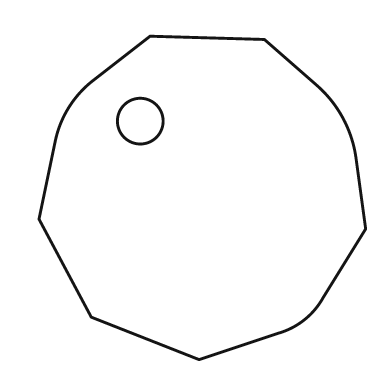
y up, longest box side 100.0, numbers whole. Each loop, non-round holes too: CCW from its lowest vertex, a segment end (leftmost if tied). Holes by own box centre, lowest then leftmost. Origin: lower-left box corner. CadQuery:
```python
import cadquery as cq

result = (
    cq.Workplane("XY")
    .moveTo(49.0, 0.0)
    .lineTo(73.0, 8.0)
    .threePointArc((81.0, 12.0), (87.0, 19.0))
    .lineTo(100.0, 40.0)
    .lineTo(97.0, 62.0)
    .threePointArc((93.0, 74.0), (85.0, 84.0))
    .lineTo(69.0, 98.0)
    .lineTo(34.0, 99.0)
    .lineTo(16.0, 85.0)
    .threePointArc((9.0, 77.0), (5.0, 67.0))
    .lineTo(0.0, 43.0)
    .lineTo(16.0, 13.0)
    .close()
    .moveTo(31.0, 73.0)
    .circle(7.0)
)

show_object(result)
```